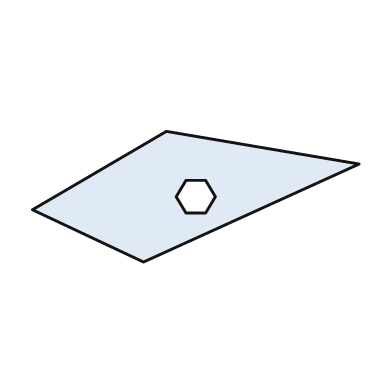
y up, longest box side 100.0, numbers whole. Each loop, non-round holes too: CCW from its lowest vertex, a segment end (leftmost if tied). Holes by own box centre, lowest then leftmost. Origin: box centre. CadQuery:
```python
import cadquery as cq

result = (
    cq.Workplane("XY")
    .moveTo(-16.0, -20.0)
    .lineTo(50.0, 10.0)
    .lineTo(-9.0, 20.0)
    .lineTo(-50.0, -4.0)
    .close()
    .moveTo(-3.0, -5.0)
    .lineTo(3.0, -5.0)
    .lineTo(6.0, 0.0)
    .lineTo(3.0, 5.0)
    .lineTo(-3.0, 5.0)
    .lineTo(-6.0, 0.0)
    .close()
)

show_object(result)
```